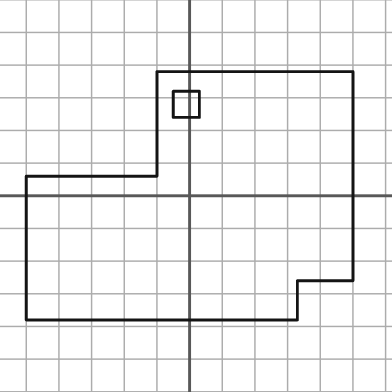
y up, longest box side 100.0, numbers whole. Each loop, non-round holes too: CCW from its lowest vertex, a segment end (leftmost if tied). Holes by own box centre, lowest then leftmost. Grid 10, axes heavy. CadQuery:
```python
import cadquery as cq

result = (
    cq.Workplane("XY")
    .moveTo(-50.0, -38.0)
    .lineTo(33.0, -38.0)
    .lineTo(33.0, -26.0)
    .lineTo(50.0, -26.0)
    .lineTo(50.0, 38.0)
    .lineTo(-10.0, 38.0)
    .lineTo(-10.0, 6.0)
    .lineTo(-50.0, 6.0)
    .close()
    .moveTo(-5.0, 24.0)
    .lineTo(3.0, 24.0)
    .lineTo(3.0, 32.0)
    .lineTo(-5.0, 32.0)
    .close()
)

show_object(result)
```